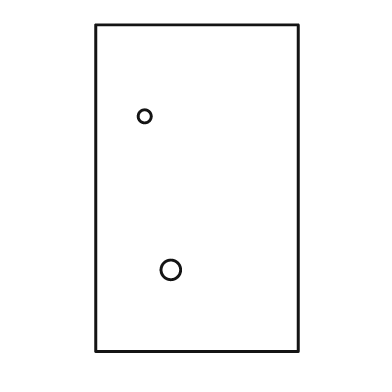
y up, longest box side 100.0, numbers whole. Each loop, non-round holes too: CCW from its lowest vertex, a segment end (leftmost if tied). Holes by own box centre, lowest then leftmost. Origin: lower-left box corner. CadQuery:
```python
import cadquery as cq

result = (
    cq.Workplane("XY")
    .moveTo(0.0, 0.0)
    .lineTo(62.0, 0.0)
    .lineTo(62.0, 100.0)
    .lineTo(0.0, 100.0)
    .close()
    .moveTo(23.0, 25.0)
    .circle(3.0)
    .moveTo(15.0, 72.0)
    .circle(2.0)
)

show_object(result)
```